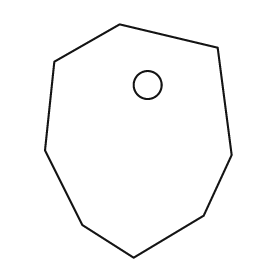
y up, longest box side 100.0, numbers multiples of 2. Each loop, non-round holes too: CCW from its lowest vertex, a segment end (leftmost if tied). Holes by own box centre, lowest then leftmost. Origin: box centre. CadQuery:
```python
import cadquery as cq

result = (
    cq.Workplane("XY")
    .moveTo(-2.0, -50.0)
    .lineTo(28.0, -32.0)
    .lineTo(40.0, -6.0)
    .lineTo(34.0, 40.0)
    .lineTo(-8.0, 50.0)
    .lineTo(-36.0, 34.0)
    .lineTo(-40.0, -4.0)
    .lineTo(-24.0, -36.0)
    .close()
    .moveTo(4.0, 24.0)
    .circle(6.0)
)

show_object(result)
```